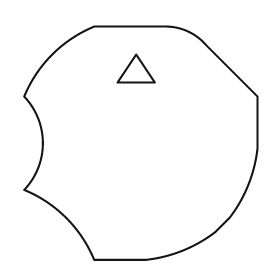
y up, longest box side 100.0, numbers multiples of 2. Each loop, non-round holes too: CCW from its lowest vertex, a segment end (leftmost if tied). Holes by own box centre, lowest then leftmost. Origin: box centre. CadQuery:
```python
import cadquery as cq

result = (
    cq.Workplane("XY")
    .moveTo(-20.0, -50.0)
    .lineTo(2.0, -50.0)
    .threePointArc((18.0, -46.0), (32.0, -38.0))
    .lineTo(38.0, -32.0)
    .threePointArc((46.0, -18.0), (50.0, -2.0))
    .lineTo(50.0, 20.0)
    .lineTo(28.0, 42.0)
    .threePointArc((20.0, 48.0), (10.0, 50.0))
    .lineTo(-20.0, 50.0)
    .threePointArc((-38.0, 38.0), (-50.0, 20.0))
    .threePointArc((-42.0, 0.0), (-50.0, -20.0))
    .threePointArc((-32.0, -32.0), (-20.0, -50.0))
    .close()
    .moveTo(-10.0, 26.0)
    .lineTo(6.0, 26.0)
    .lineTo(-2.0, 38.0)
    .close()
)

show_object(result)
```